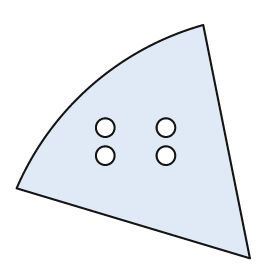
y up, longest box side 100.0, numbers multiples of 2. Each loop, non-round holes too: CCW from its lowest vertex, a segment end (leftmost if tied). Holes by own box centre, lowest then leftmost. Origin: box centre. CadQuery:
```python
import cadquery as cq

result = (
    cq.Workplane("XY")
    .moveTo(50.0, -50.0)
    .lineTo(30.0, 50.0)
    .threePointArc((-18.0, 24.0), (-50.0, -20.0))
    .close()
    .moveTo(-12.0, -6.0)
    .circle(4.0)
    .moveTo(14.0, -6.0)
    .circle(4.0)
    .moveTo(-12.0, 6.0)
    .circle(4.0)
    .moveTo(14.0, 6.0)
    .circle(4.0)
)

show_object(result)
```